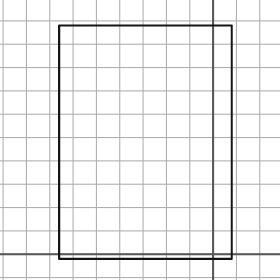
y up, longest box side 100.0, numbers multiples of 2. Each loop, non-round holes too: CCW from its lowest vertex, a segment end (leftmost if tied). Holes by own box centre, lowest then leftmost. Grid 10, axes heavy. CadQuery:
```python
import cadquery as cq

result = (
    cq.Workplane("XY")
    .moveTo(-66.0, -2.0)
    .lineTo(8.0, -2.0)
    .lineTo(8.0, 98.0)
    .lineTo(-66.0, 98.0)
    .close()
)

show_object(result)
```